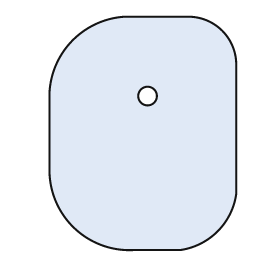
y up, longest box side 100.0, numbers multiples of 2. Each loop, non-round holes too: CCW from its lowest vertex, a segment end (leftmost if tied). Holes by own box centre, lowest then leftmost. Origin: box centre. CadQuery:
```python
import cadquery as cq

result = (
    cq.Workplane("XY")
    .moveTo(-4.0, -50.0)
    .lineTo(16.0, -50.0)
    .threePointArc((32.0, -42.0), (40.0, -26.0))
    .lineTo(40.0, 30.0)
    .threePointArc((34.0, 44.0), (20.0, 50.0))
    .lineTo(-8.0, 50.0)
    .threePointArc((-30.0, 40.0), (-40.0, 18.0))
    .lineTo(-40.0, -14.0)
    .threePointArc((-30.0, -40.0), (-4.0, -50.0))
    .close()
    .moveTo(2.0, 16.0)
    .circle(4.0)
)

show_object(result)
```